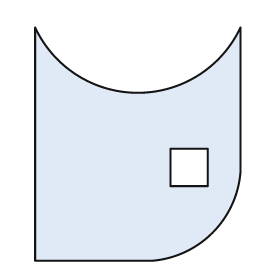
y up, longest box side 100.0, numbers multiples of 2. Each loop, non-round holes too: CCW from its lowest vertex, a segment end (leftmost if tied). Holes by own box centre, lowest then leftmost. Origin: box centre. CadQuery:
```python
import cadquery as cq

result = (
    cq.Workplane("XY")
    .moveTo(-44.0, -50.0)
    .lineTo(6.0, -50.0)
    .threePointArc((32.0, -38.0), (44.0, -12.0))
    .lineTo(44.0, 50.0)
    .threePointArc((0.0, 22.0), (-44.0, 50.0))
    .close()
    .moveTo(14.0, -18.0)
    .lineTo(30.0, -18.0)
    .lineTo(30.0, -2.0)
    .lineTo(14.0, -2.0)
    .close()
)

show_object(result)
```